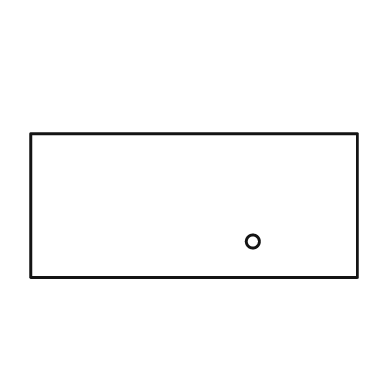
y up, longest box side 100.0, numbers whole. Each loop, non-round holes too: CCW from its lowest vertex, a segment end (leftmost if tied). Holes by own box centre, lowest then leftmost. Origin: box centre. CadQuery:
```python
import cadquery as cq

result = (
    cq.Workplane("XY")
    .moveTo(-50.0, -22.0)
    .lineTo(50.0, -22.0)
    .lineTo(50.0, 22.0)
    .lineTo(-50.0, 22.0)
    .close()
    .moveTo(18.0, -11.0)
    .circle(2.0)
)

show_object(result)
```